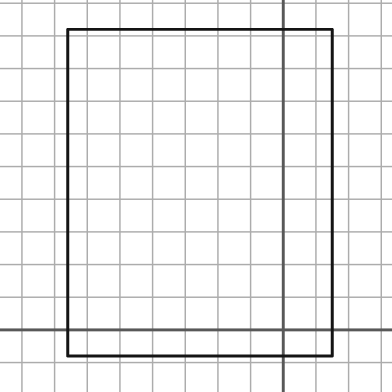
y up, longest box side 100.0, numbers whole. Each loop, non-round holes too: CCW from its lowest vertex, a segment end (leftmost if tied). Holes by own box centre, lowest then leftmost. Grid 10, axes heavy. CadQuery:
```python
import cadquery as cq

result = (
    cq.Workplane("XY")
    .moveTo(-66.0, -8.0)
    .lineTo(15.0, -8.0)
    .lineTo(15.0, 92.0)
    .lineTo(-66.0, 92.0)
    .close()
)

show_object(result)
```